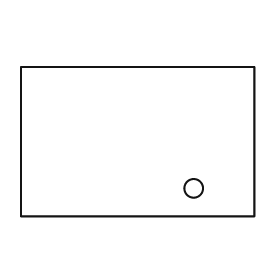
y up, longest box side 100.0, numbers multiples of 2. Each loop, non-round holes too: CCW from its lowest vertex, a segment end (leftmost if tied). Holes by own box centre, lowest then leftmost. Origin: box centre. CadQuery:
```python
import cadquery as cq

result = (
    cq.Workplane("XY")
    .moveTo(-50.0, -32.0)
    .lineTo(50.0, -32.0)
    .lineTo(50.0, 32.0)
    .lineTo(-50.0, 32.0)
    .close()
    .moveTo(24.0, -20.0)
    .circle(4.0)
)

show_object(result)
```